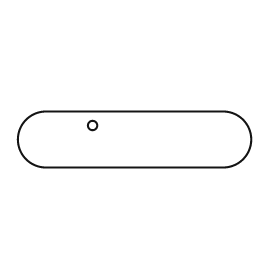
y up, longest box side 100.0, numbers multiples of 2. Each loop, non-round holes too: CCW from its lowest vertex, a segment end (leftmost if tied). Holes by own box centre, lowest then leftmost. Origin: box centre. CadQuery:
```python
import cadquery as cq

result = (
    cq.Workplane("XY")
    .moveTo(-38.0, -12.0)
    .lineTo(38.0, -12.0)
    .threePointArc((50.0, 0.0), (38.0, 12.0))
    .lineTo(-38.0, 12.0)
    .threePointArc((-50.0, 0.0), (-38.0, -12.0))
    .close()
    .moveTo(-18.0, 6.0)
    .circle(2.0)
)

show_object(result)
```